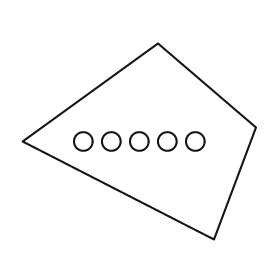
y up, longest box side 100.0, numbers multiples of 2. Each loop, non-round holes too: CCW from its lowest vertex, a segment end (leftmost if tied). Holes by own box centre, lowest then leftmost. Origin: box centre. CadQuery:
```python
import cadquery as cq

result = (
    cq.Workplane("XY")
    .moveTo(32.0, -42.0)
    .lineTo(50.0, 6.0)
    .lineTo(8.0, 42.0)
    .lineTo(-50.0, 0.0)
    .close()
    .moveTo(-24.0, 0.0)
    .circle(4.0)
    .moveTo(-12.0, 0.0)
    .circle(4.0)
    .moveTo(0.0, 0.0)
    .circle(4.0)
    .moveTo(12.0, 0.0)
    .circle(4.0)
    .moveTo(24.0, 0.0)
    .circle(4.0)
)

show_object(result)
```